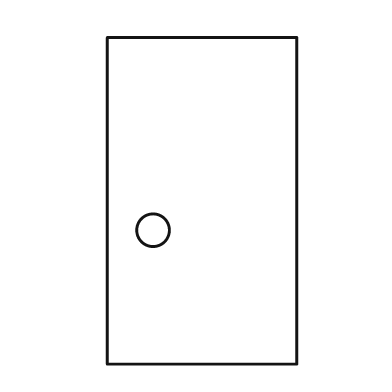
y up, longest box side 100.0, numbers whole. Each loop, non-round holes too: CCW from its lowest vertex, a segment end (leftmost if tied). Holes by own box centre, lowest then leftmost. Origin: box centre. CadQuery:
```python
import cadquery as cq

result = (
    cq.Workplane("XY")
    .moveTo(-29.0, -50.0)
    .lineTo(29.0, -50.0)
    .lineTo(29.0, 50.0)
    .lineTo(-29.0, 50.0)
    .close()
    .moveTo(-15.0, -9.0)
    .circle(5.0)
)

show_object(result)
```